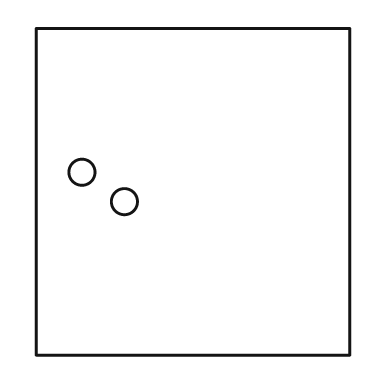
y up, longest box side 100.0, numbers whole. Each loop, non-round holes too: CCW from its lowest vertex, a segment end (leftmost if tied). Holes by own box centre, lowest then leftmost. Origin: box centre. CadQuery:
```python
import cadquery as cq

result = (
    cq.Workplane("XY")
    .moveTo(-48.0, -50.0)
    .lineTo(48.0, -50.0)
    .lineTo(48.0, 50.0)
    .lineTo(-48.0, 50.0)
    .close()
    .moveTo(-21.0, -3.0)
    .circle(4.0)
    .moveTo(-34.0, 6.0)
    .circle(4.0)
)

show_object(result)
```